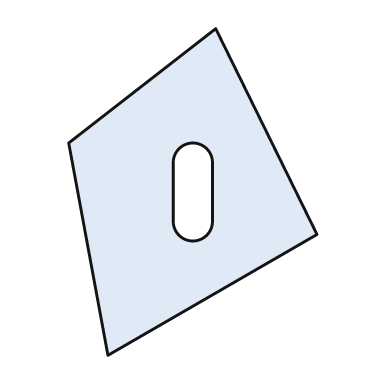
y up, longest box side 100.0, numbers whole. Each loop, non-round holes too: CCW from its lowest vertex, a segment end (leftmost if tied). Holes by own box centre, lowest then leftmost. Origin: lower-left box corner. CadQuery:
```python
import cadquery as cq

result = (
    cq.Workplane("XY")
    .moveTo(12.0, 0.0)
    .lineTo(76.0, 37.0)
    .lineTo(45.0, 100.0)
    .lineTo(0.0, 65.0)
    .close()
    .moveTo(32.0, 41.0)
    .threePointArc((38.0, 35.0), (44.0, 41.0))
    .lineTo(44.0, 59.0)
    .threePointArc((38.0, 65.0), (32.0, 59.0))
    .close()
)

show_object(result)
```